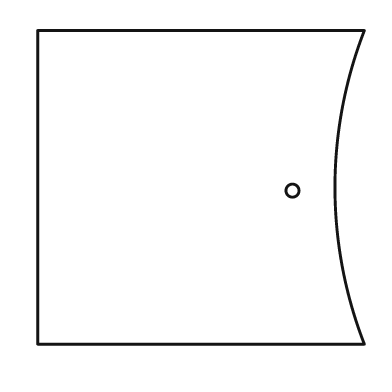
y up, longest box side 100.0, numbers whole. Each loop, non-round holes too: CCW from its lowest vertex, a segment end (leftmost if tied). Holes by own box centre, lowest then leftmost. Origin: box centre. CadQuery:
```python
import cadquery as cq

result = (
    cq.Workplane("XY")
    .moveTo(-50.0, -48.0)
    .lineTo(50.0, -48.0)
    .threePointArc((41.0, 0.0), (50.0, 48.0))
    .lineTo(-50.0, 48.0)
    .close()
    .moveTo(28.0, -1.0)
    .circle(2.0)
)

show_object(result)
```